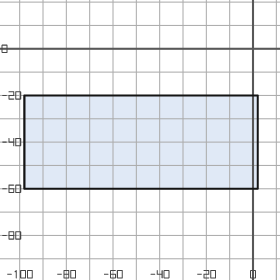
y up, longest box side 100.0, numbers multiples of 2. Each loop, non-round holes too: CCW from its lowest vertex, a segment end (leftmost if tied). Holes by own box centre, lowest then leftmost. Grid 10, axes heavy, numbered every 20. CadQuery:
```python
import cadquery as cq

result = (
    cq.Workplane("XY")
    .moveTo(-98.0, -60.0)
    .lineTo(2.0, -60.0)
    .lineTo(2.0, -20.0)
    .lineTo(-98.0, -20.0)
    .close()
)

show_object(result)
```